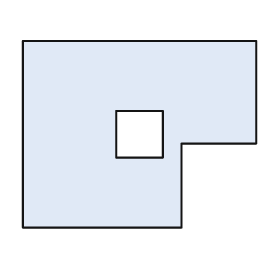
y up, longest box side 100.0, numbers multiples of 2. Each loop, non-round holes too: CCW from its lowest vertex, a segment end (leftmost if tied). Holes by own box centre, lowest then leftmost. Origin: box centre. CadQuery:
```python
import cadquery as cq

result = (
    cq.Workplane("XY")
    .moveTo(-50.0, -40.0)
    .lineTo(18.0, -40.0)
    .lineTo(18.0, -4.0)
    .lineTo(50.0, -4.0)
    .lineTo(50.0, 40.0)
    .lineTo(-50.0, 40.0)
    .close()
    .moveTo(-10.0, -10.0)
    .lineTo(10.0, -10.0)
    .lineTo(10.0, 10.0)
    .lineTo(-10.0, 10.0)
    .close()
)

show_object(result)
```